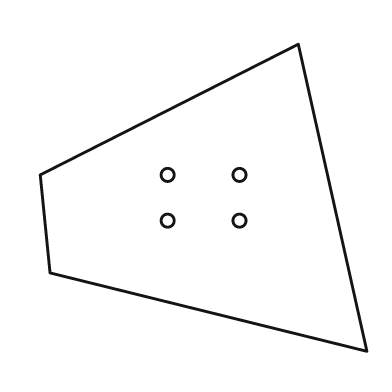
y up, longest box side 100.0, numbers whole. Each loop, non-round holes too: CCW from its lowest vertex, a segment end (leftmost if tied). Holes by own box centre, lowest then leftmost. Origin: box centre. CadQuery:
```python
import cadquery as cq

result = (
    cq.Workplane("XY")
    .moveTo(50.0, -47.0)
    .lineTo(29.0, 47.0)
    .lineTo(-50.0, 7.0)
    .lineTo(-47.0, -23.0)
    .close()
    .moveTo(-11.0, -7.0)
    .circle(2.0)
    .moveTo(11.0, -7.0)
    .circle(2.0)
    .moveTo(-11.0, 7.0)
    .circle(2.0)
    .moveTo(11.0, 7.0)
    .circle(2.0)
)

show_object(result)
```